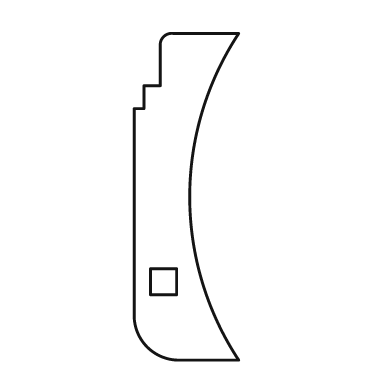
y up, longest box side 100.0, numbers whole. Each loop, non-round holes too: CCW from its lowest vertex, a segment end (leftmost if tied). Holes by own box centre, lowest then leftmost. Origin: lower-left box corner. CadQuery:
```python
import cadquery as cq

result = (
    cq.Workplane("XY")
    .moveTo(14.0, 0.0)
    .lineTo(32.0, 0.0)
    .threePointArc((17.0, 50.0), (32.0, 100.0))
    .lineTo(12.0, 100.0)
    .threePointArc((9.0, 99.0), (8.0, 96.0))
    .lineTo(8.0, 84.0)
    .lineTo(3.0, 84.0)
    .lineTo(3.0, 77.0)
    .lineTo(0.0, 77.0)
    .lineTo(0.0, 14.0)
    .threePointArc((4.0, 4.0), (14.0, 0.0))
    .close()
    .moveTo(5.0, 20.0)
    .lineTo(13.0, 20.0)
    .lineTo(13.0, 28.0)
    .lineTo(5.0, 28.0)
    .close()
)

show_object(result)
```